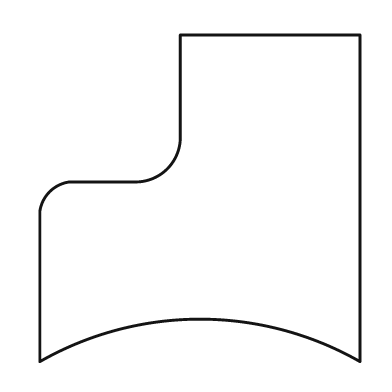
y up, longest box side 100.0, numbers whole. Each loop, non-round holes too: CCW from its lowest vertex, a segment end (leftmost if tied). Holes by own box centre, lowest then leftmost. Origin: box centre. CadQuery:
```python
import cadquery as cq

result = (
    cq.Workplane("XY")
    .moveTo(-49.0, -50.0)
    .threePointArc((0.0, -37.0), (49.0, -50.0))
    .lineTo(49.0, 50.0)
    .lineTo(-6.0, 50.0)
    .lineTo(-6.0, 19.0)
    .threePointArc((-10.0, 9.0), (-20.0, 5.0))
    .lineTo(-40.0, 5.0)
    .threePointArc((-46.0, 2.0), (-49.0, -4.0))
    .close()
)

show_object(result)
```